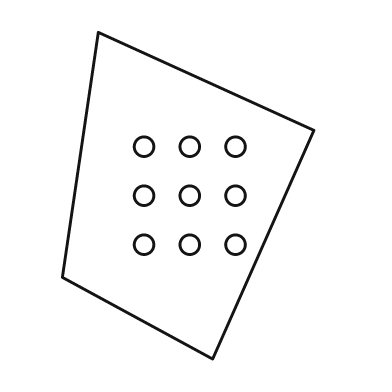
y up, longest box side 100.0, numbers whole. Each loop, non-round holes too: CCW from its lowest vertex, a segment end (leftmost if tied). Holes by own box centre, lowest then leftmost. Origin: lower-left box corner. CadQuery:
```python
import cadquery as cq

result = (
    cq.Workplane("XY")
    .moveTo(46.0, 0.0)
    .lineTo(77.0, 70.0)
    .lineTo(11.0, 100.0)
    .lineTo(0.0, 25.0)
    .close()
    .moveTo(25.0, 35.0)
    .circle(3.0)
    .moveTo(39.0, 35.0)
    .circle(3.0)
    .moveTo(53.0, 35.0)
    .circle(3.0)
    .moveTo(25.0, 50.0)
    .circle(3.0)
    .moveTo(39.0, 50.0)
    .circle(3.0)
    .moveTo(53.0, 50.0)
    .circle(3.0)
    .moveTo(25.0, 65.0)
    .circle(3.0)
    .moveTo(39.0, 65.0)
    .circle(3.0)
    .moveTo(53.0, 65.0)
    .circle(3.0)
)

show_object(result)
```